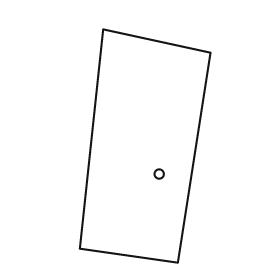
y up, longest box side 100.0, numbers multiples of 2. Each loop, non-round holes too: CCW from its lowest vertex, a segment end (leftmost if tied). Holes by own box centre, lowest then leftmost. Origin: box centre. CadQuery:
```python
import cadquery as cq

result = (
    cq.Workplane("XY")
    .moveTo(14.0, -50.0)
    .lineTo(28.0, 40.0)
    .lineTo(-18.0, 50.0)
    .lineTo(-28.0, -44.0)
    .close()
    .moveTo(6.0, -12.0)
    .circle(2.0)
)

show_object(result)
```